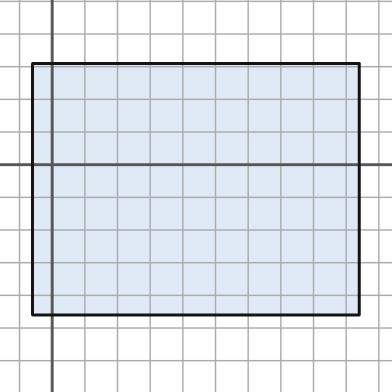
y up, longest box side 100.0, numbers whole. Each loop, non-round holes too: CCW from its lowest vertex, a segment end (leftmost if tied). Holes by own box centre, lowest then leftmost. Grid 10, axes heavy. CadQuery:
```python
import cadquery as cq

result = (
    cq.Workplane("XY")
    .moveTo(-6.0, -46.0)
    .lineTo(94.0, -46.0)
    .lineTo(94.0, 31.0)
    .lineTo(-6.0, 31.0)
    .close()
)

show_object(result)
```